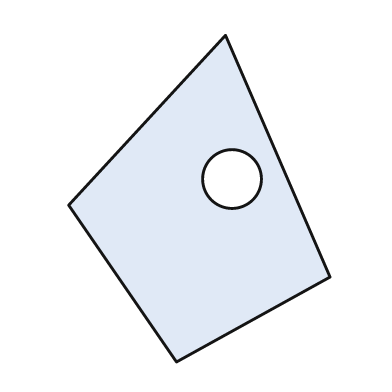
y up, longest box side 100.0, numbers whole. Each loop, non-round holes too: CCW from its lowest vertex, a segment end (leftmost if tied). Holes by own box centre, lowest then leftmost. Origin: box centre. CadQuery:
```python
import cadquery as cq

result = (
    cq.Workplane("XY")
    .moveTo(-7.0, -50.0)
    .lineTo(40.0, -24.0)
    .lineTo(8.0, 50.0)
    .lineTo(-40.0, -2.0)
    .close()
    .moveTo(10.0, 6.0)
    .circle(9.0)
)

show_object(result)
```